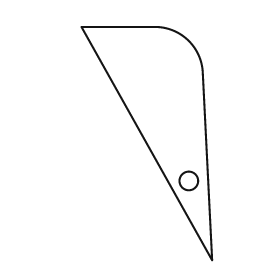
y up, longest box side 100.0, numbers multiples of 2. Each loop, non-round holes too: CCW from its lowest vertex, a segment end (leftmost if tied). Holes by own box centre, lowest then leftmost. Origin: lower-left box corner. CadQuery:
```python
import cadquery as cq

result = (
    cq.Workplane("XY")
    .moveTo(56.0, 0.0)
    .lineTo(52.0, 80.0)
    .threePointArc((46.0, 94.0), (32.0, 100.0))
    .lineTo(0.0, 100.0)
    .close()
    .moveTo(46.0, 34.0)
    .circle(4.0)
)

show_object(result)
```